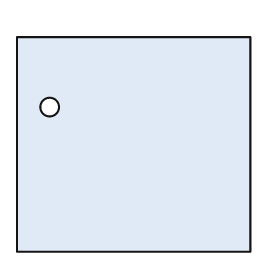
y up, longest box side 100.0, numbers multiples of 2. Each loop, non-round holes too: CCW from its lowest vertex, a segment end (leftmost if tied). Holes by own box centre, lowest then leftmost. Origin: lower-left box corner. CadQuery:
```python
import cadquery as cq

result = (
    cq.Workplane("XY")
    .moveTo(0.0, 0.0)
    .lineTo(100.0, 0.0)
    .lineTo(100.0, 92.0)
    .lineTo(0.0, 92.0)
    .close()
    .moveTo(14.0, 62.0)
    .circle(4.0)
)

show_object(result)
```